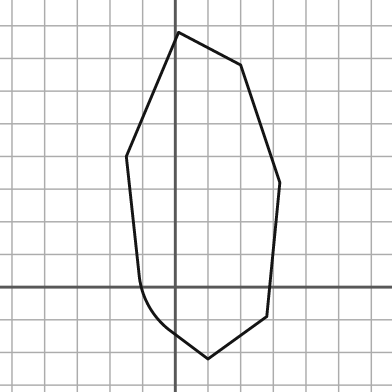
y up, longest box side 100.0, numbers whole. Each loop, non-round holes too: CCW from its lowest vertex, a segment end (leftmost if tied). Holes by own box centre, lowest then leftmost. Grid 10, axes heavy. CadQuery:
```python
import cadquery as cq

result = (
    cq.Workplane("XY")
    .moveTo(10.0, -22.0)
    .lineTo(28.0, -9.0)
    .lineTo(32.0, 32.0)
    .lineTo(20.0, 68.0)
    .lineTo(1.0, 78.0)
    .lineTo(-15.0, 40.0)
    .lineTo(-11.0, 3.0)
    .threePointArc((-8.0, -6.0), (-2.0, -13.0))
    .close()
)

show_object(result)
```